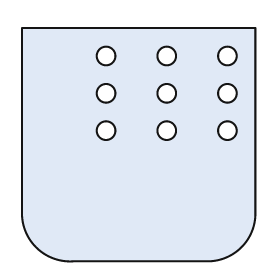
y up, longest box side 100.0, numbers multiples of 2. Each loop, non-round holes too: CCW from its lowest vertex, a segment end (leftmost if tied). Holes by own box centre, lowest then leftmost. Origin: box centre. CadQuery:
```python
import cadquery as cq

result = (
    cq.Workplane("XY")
    .moveTo(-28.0, -50.0)
    .lineTo(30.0, -50.0)
    .threePointArc((44.0, -44.0), (50.0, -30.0))
    .lineTo(50.0, 50.0)
    .lineTo(-50.0, 50.0)
    .lineTo(-50.0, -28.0)
    .threePointArc((-44.0, -44.0), (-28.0, -50.0))
    .close()
    .moveTo(-14.0, 6.0)
    .circle(4.0)
    .moveTo(12.0, 6.0)
    .circle(4.0)
    .moveTo(38.0, 6.0)
    .circle(4.0)
    .moveTo(-14.0, 22.0)
    .circle(4.0)
    .moveTo(12.0, 22.0)
    .circle(4.0)
    .moveTo(38.0, 22.0)
    .circle(4.0)
    .moveTo(-14.0, 38.0)
    .circle(4.0)
    .moveTo(12.0, 38.0)
    .circle(4.0)
    .moveTo(38.0, 38.0)
    .circle(4.0)
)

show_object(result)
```